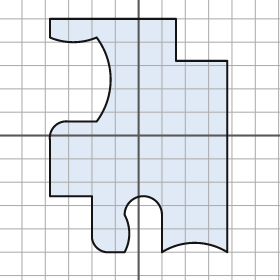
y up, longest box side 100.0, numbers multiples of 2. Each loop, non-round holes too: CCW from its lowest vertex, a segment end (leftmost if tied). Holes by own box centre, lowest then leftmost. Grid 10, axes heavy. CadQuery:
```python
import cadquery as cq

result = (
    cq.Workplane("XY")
    .moveTo(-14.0, -50.0)
    .lineTo(-6.0, -50.0)
    .threePointArc((-4.0, -42.0), (-6.0, -34.0))
    .threePointArc((2.0, -26.0), (10.0, -34.0))
    .lineTo(10.0, -50.0)
    .threePointArc((24.0, -46.0), (38.0, -50.0))
    .lineTo(38.0, 32.0)
    .lineTo(16.0, 32.0)
    .lineTo(16.0, 50.0)
    .lineTo(-38.0, 50.0)
    .lineTo(-38.0, 42.0)
    .threePointArc((-28.0, 40.0), (-18.0, 42.0))
    .threePointArc((-12.0, 24.0), (-18.0, 6.0))
    .lineTo(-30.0, 6.0)
    .threePointArc((-36.0, 4.0), (-38.0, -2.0))
    .lineTo(-38.0, -26.0)
    .lineTo(-20.0, -26.0)
    .lineTo(-20.0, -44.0)
    .threePointArc((-18.0, -48.0), (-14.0, -50.0))
    .close()
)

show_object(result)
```